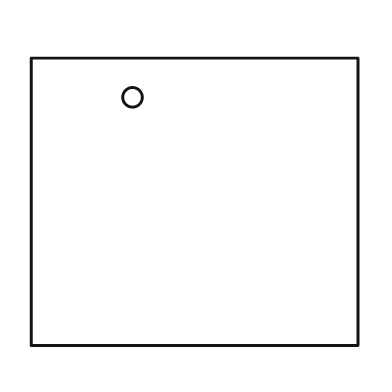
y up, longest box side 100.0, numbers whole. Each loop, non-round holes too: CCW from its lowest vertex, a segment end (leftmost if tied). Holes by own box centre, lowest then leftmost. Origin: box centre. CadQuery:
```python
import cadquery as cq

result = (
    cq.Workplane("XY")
    .moveTo(-50.0, -44.0)
    .lineTo(50.0, -44.0)
    .lineTo(50.0, 44.0)
    .lineTo(-50.0, 44.0)
    .close()
    .moveTo(-19.0, 32.0)
    .circle(3.0)
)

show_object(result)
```